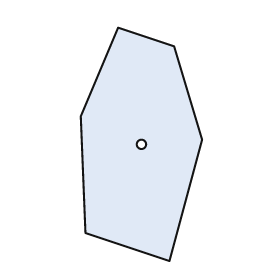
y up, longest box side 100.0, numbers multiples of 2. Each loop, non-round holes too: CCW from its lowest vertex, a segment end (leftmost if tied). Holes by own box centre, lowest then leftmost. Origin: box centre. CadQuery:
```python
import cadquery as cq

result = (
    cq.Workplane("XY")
    .moveTo(12.0, -50.0)
    .lineTo(26.0, 2.0)
    .lineTo(14.0, 42.0)
    .lineTo(-10.0, 50.0)
    .lineTo(-26.0, 12.0)
    .lineTo(-24.0, -38.0)
    .close()
    .moveTo(0.0, 0.0)
    .circle(2.0)
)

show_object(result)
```